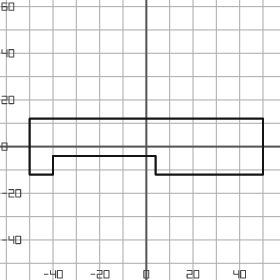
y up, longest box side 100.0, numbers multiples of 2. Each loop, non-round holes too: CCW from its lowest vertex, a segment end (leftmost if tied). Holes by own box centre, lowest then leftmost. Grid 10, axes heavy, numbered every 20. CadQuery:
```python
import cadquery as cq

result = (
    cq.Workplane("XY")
    .moveTo(-50.0, -12.0)
    .lineTo(-40.0, -12.0)
    .lineTo(-40.0, -4.0)
    .lineTo(4.0, -4.0)
    .lineTo(4.0, -12.0)
    .lineTo(50.0, -12.0)
    .lineTo(50.0, 12.0)
    .lineTo(-50.0, 12.0)
    .close()
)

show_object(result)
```